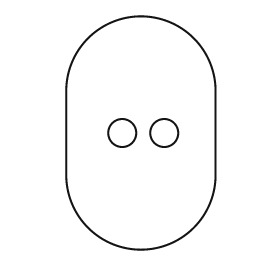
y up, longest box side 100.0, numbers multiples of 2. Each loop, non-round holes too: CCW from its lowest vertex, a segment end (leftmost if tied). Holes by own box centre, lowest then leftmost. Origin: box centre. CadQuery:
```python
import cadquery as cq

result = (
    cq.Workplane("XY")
    .moveTo(-32.0, -18.0)
    .threePointArc((0.0, -50.0), (32.0, -18.0))
    .lineTo(32.0, 18.0)
    .threePointArc((0.0, 50.0), (-32.0, 18.0))
    .close()
    .moveTo(-8.0, 0.0)
    .circle(6.0)
    .moveTo(10.0, 0.0)
    .circle(6.0)
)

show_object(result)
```